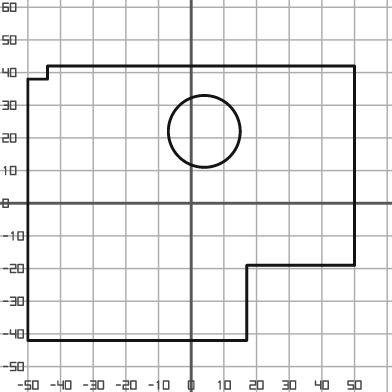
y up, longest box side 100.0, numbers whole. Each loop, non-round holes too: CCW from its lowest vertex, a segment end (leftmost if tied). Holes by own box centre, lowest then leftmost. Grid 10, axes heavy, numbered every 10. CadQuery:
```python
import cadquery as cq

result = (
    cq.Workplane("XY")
    .moveTo(-50.0, -42.0)
    .lineTo(17.0, -42.0)
    .lineTo(17.0, -19.0)
    .lineTo(50.0, -19.0)
    .lineTo(50.0, 42.0)
    .lineTo(-44.0, 42.0)
    .lineTo(-44.0, 38.0)
    .lineTo(-50.0, 38.0)
    .close()
    .moveTo(4.0, 22.0)
    .circle(11.0)
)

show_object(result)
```